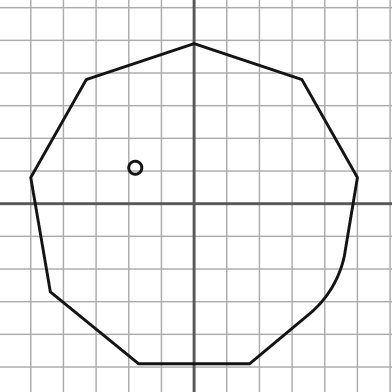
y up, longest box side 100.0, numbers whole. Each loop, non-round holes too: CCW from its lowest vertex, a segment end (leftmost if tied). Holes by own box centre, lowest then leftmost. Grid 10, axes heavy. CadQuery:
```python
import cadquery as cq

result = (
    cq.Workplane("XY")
    .moveTo(-17.0, -49.0)
    .lineTo(17.0, -49.0)
    .lineTo(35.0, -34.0)
    .threePointArc((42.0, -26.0), (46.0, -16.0))
    .lineTo(50.0, 8.0)
    .lineTo(33.0, 38.0)
    .lineTo(0.0, 49.0)
    .lineTo(-33.0, 38.0)
    .lineTo(-50.0, 8.0)
    .lineTo(-44.0, -27.0)
    .close()
    .moveTo(-18.0, 11.0)
    .circle(2.0)
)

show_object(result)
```